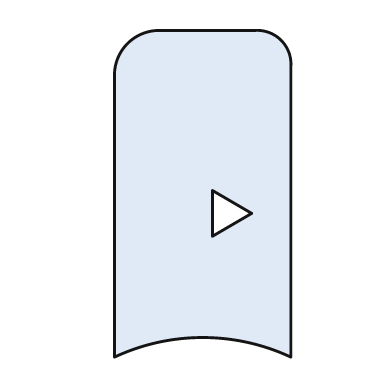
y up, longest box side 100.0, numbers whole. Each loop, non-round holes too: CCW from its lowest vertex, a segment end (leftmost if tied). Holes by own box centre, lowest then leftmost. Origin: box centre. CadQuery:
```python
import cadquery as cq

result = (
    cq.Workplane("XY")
    .moveTo(-27.0, -50.0)
    .threePointArc((0.0, -44.0), (27.0, -50.0))
    .lineTo(27.0, 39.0)
    .threePointArc((24.0, 47.0), (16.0, 50.0))
    .lineTo(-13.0, 50.0)
    .threePointArc((-23.0, 46.0), (-27.0, 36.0))
    .close()
    .moveTo(3.0, -13.0)
    .lineTo(15.0, -6.0)
    .lineTo(3.0, 1.0)
    .close()
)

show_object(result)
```